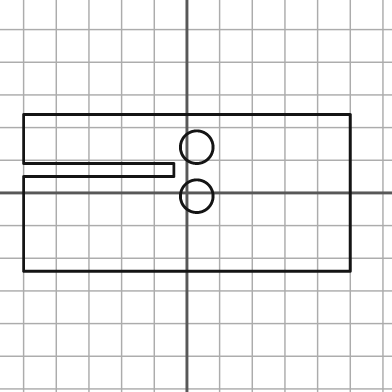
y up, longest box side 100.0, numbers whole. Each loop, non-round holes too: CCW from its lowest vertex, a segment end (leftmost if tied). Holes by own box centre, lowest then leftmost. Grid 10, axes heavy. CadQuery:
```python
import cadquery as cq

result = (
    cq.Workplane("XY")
    .moveTo(-50.0, -24.0)
    .lineTo(50.0, -24.0)
    .lineTo(50.0, 24.0)
    .lineTo(-50.0, 24.0)
    .lineTo(-50.0, 9.0)
    .lineTo(-4.0, 9.0)
    .lineTo(-4.0, 5.0)
    .lineTo(-50.0, 5.0)
    .close()
    .moveTo(3.0, -1.0)
    .circle(5.0)
    .moveTo(3.0, 14.0)
    .circle(5.0)
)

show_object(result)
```